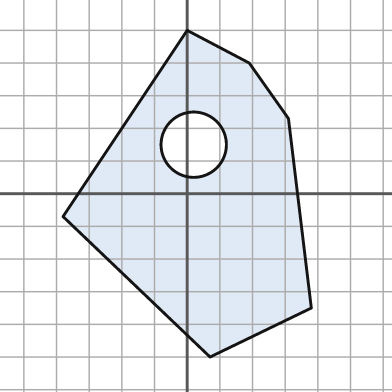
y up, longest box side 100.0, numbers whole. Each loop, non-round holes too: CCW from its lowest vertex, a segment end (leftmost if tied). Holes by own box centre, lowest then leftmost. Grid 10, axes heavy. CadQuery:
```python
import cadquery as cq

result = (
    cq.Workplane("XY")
    .moveTo(7.0, -50.0)
    .lineTo(38.0, -35.0)
    .lineTo(31.0, 23.0)
    .lineTo(19.0, 40.0)
    .lineTo(0.0, 50.0)
    .lineTo(-38.0, -7.0)
    .close()
    .moveTo(2.0, 15.0)
    .circle(10.0)
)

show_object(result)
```